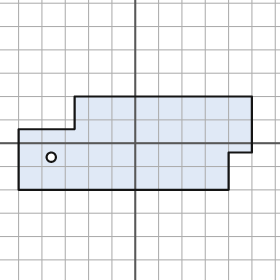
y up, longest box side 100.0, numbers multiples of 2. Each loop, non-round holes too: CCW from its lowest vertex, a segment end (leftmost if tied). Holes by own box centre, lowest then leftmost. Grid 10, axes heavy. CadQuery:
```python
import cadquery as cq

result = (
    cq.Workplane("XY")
    .moveTo(-50.0, -20.0)
    .lineTo(40.0, -20.0)
    .lineTo(40.0, -4.0)
    .lineTo(50.0, -4.0)
    .lineTo(50.0, 20.0)
    .lineTo(-26.0, 20.0)
    .lineTo(-26.0, 6.0)
    .lineTo(-50.0, 6.0)
    .close()
    .moveTo(-36.0, -6.0)
    .circle(2.0)
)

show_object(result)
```